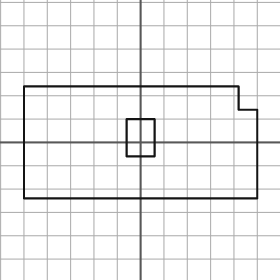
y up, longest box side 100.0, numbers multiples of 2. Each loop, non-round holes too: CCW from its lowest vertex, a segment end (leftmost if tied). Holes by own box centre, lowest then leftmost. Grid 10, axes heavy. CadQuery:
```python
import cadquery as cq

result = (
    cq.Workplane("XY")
    .moveTo(-50.0, -24.0)
    .lineTo(50.0, -24.0)
    .lineTo(50.0, 14.0)
    .lineTo(42.0, 14.0)
    .lineTo(42.0, 24.0)
    .lineTo(-50.0, 24.0)
    .close()
    .moveTo(-6.0, -6.0)
    .lineTo(6.0, -6.0)
    .lineTo(6.0, 10.0)
    .lineTo(-6.0, 10.0)
    .close()
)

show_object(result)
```